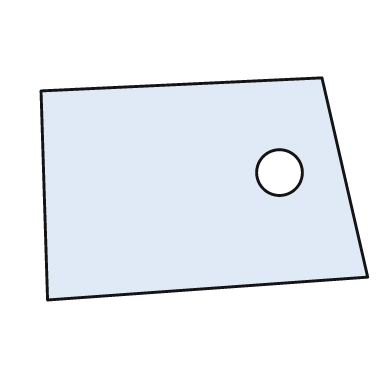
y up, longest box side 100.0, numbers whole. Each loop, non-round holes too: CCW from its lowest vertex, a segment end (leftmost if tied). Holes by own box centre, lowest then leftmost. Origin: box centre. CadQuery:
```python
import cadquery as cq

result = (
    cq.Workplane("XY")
    .moveTo(-48.0, -34.0)
    .lineTo(50.0, -27.0)
    .lineTo(36.0, 34.0)
    .lineTo(-50.0, 30.0)
    .close()
    .moveTo(23.0, 5.0)
    .circle(7.0)
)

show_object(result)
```